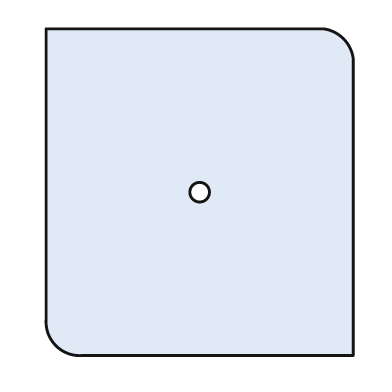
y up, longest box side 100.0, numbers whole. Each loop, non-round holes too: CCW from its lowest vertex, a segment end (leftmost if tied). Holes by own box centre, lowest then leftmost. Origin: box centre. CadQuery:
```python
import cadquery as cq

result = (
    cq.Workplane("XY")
    .moveTo(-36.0, -50.0)
    .lineTo(47.0, -50.0)
    .lineTo(47.0, 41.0)
    .threePointArc((44.0, 47.0), (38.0, 50.0))
    .lineTo(-47.0, 50.0)
    .lineTo(-47.0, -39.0)
    .threePointArc((-44.0, -47.0), (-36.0, -50.0))
    .close()
    .moveTo(0.0, 0.0)
    .circle(3.0)
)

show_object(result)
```